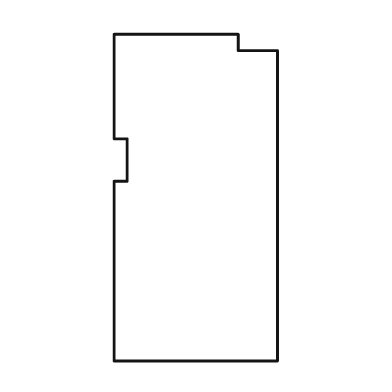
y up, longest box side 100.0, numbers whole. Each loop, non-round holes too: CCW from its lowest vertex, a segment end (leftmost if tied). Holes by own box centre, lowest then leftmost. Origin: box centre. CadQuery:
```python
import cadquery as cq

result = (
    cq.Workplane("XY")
    .moveTo(-25.0, -50.0)
    .lineTo(25.0, -50.0)
    .lineTo(25.0, 45.0)
    .lineTo(13.0, 45.0)
    .lineTo(13.0, 50.0)
    .lineTo(-25.0, 50.0)
    .lineTo(-25.0, 18.0)
    .lineTo(-21.0, 18.0)
    .lineTo(-21.0, 5.0)
    .lineTo(-25.0, 5.0)
    .close()
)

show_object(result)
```